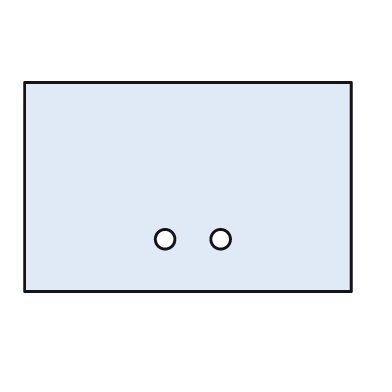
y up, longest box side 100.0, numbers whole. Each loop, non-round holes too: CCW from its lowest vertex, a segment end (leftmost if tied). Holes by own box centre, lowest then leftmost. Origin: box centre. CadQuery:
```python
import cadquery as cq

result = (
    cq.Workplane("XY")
    .moveTo(-50.0, -32.0)
    .lineTo(50.0, -32.0)
    .lineTo(50.0, 32.0)
    .lineTo(-50.0, 32.0)
    .close()
    .moveTo(-7.0, -16.0)
    .circle(3.0)
    .moveTo(10.0, -16.0)
    .circle(3.0)
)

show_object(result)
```